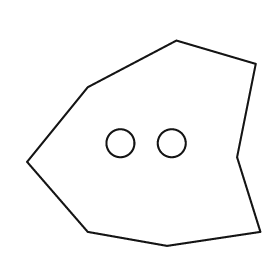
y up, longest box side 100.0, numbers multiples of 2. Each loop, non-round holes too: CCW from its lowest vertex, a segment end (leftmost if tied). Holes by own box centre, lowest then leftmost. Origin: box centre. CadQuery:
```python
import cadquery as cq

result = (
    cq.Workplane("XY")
    .moveTo(10.0, -44.0)
    .lineTo(50.0, -38.0)
    .lineTo(40.0, -6.0)
    .lineTo(48.0, 34.0)
    .lineTo(14.0, 44.0)
    .lineTo(-24.0, 24.0)
    .lineTo(-50.0, -8.0)
    .lineTo(-24.0, -38.0)
    .close()
    .moveTo(-10.0, 0.0)
    .circle(6.0)
    .moveTo(12.0, 0.0)
    .circle(6.0)
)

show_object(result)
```